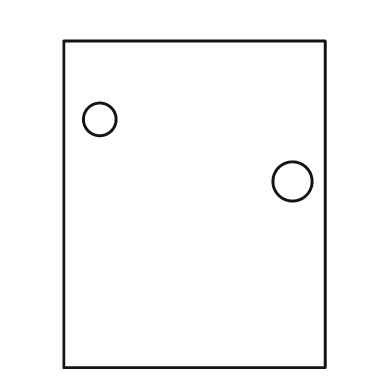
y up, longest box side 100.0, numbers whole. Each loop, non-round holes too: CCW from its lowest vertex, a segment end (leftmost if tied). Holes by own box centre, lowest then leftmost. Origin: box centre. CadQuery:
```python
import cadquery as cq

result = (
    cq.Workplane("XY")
    .moveTo(-40.0, -50.0)
    .lineTo(40.0, -50.0)
    .lineTo(40.0, 50.0)
    .lineTo(-40.0, 50.0)
    .close()
    .moveTo(30.0, 7.0)
    .circle(6.0)
    .moveTo(-29.0, 26.0)
    .circle(5.0)
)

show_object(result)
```